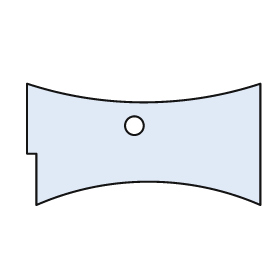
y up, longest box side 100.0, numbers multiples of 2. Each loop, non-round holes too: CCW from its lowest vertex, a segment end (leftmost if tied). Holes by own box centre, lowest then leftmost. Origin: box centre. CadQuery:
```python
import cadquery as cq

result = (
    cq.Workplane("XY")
    .moveTo(-46.0, -26.0)
    .threePointArc((2.0, -16.0), (50.0, -26.0))
    .lineTo(50.0, 26.0)
    .threePointArc((0.0, 18.0), (-50.0, 26.0))
    .lineTo(-50.0, -4.0)
    .lineTo(-46.0, -4.0)
    .close()
    .moveTo(-4.0, 8.0)
    .circle(4.0)
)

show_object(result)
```